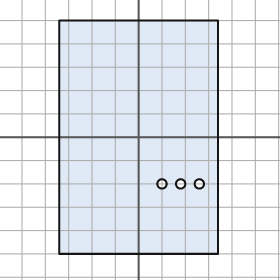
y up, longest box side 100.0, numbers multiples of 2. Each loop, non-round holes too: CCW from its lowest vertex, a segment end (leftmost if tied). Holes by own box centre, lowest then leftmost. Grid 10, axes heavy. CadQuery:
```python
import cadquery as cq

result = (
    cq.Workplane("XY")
    .moveTo(-34.0, -50.0)
    .lineTo(34.0, -50.0)
    .lineTo(34.0, 50.0)
    .lineTo(-34.0, 50.0)
    .close()
    .moveTo(10.0, -20.0)
    .circle(2.0)
    .moveTo(18.0, -20.0)
    .circle(2.0)
    .moveTo(26.0, -20.0)
    .circle(2.0)
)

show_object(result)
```